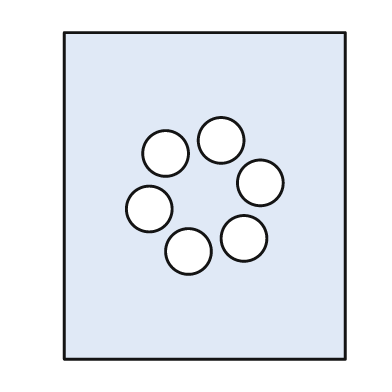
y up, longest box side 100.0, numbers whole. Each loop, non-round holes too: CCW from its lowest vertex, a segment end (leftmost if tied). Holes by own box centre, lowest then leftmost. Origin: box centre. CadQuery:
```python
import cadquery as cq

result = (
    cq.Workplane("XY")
    .moveTo(-43.0, -50.0)
    .lineTo(43.0, -50.0)
    .lineTo(43.0, 50.0)
    .lineTo(-43.0, 50.0)
    .close()
    .moveTo(-5.0, -17.0)
    .circle(7.0)
    .moveTo(12.0, -13.0)
    .circle(7.0)
    .moveTo(-17.0, -4.0)
    .circle(7.0)
    .moveTo(17.0, 4.0)
    .circle(7.0)
    .moveTo(-12.0, 13.0)
    .circle(7.0)
    .moveTo(5.0, 17.0)
    .circle(7.0)
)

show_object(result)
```